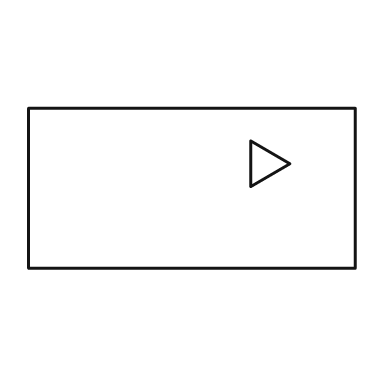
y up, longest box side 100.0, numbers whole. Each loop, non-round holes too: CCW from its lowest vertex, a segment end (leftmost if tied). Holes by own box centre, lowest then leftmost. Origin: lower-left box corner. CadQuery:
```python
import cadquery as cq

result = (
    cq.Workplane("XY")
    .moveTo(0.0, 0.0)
    .lineTo(100.0, 0.0)
    .lineTo(100.0, 49.0)
    .lineTo(0.0, 49.0)
    .close()
    .moveTo(68.0, 25.0)
    .lineTo(80.0, 32.0)
    .lineTo(68.0, 39.0)
    .close()
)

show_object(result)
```